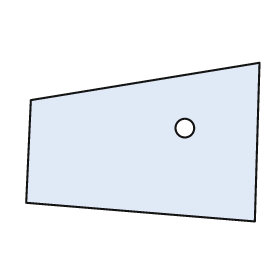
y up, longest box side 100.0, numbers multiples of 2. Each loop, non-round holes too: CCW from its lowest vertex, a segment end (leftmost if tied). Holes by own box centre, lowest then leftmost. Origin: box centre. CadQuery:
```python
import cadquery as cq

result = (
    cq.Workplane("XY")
    .moveTo(48.0, -34.0)
    .lineTo(50.0, 34.0)
    .lineTo(-48.0, 18.0)
    .lineTo(-50.0, -26.0)
    .close()
    .moveTo(18.0, 6.0)
    .circle(4.0)
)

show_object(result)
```